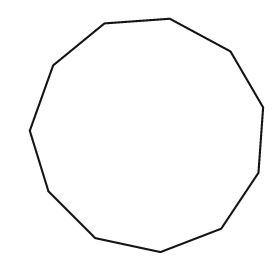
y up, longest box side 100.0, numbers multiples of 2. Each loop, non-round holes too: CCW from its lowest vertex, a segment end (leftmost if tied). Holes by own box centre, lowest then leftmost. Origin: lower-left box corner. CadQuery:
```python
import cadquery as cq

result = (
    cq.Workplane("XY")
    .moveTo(56.0, 0.0)
    .lineTo(82.0, 10.0)
    .lineTo(98.0, 34.0)
    .lineTo(100.0, 62.0)
    .lineTo(86.0, 86.0)
    .lineTo(60.0, 100.0)
    .lineTo(32.0, 98.0)
    .lineTo(10.0, 80.0)
    .lineTo(0.0, 52.0)
    .lineTo(8.0, 26.0)
    .lineTo(28.0, 6.0)
    .close()
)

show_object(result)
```